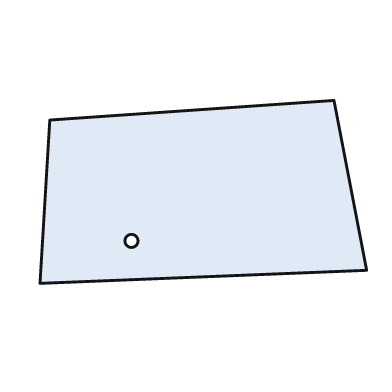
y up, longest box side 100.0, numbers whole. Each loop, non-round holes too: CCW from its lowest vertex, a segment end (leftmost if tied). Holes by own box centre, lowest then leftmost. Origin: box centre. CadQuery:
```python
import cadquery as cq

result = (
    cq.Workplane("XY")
    .moveTo(-50.0, -28.0)
    .lineTo(50.0, -24.0)
    .lineTo(40.0, 28.0)
    .lineTo(-47.0, 22.0)
    .close()
    .moveTo(-22.0, -15.0)
    .circle(2.0)
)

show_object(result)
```